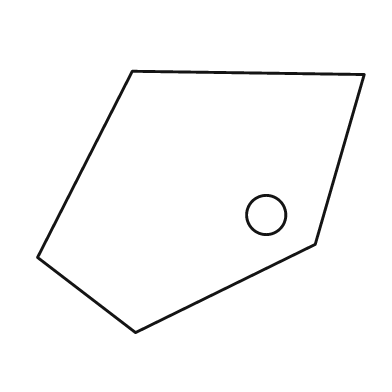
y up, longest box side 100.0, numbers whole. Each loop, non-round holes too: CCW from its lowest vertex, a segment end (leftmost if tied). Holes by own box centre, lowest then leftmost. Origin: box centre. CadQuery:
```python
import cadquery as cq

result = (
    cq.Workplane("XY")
    .moveTo(-20.0, -40.0)
    .lineTo(35.0, -13.0)
    .lineTo(50.0, 39.0)
    .lineTo(-21.0, 40.0)
    .lineTo(-50.0, -17.0)
    .close()
    .moveTo(20.0, -4.0)
    .circle(6.0)
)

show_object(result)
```